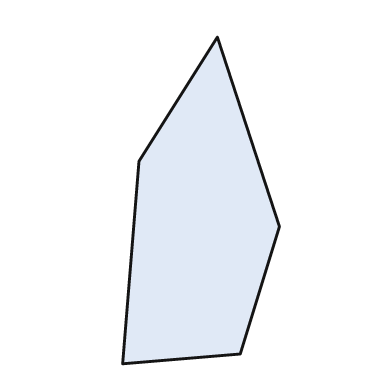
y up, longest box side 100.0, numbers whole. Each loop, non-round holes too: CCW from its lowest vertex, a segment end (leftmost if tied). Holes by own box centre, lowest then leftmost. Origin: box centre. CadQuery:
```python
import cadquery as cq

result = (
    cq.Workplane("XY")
    .moveTo(-24.0, -50.0)
    .lineTo(12.0, -47.0)
    .lineTo(24.0, -8.0)
    .lineTo(5.0, 50.0)
    .lineTo(-19.0, 12.0)
    .close()
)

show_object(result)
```